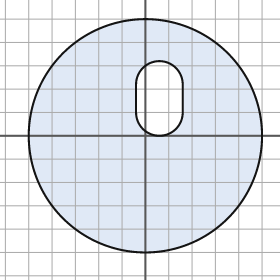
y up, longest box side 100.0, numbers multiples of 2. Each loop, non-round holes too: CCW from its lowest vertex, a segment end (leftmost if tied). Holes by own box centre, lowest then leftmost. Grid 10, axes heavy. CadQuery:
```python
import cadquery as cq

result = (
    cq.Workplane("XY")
    .moveTo(0.0, 0.0)
    .circle(50.0)
    .moveTo(-4.0, 10.0)
    .threePointArc((6.0, 0.0), (16.0, 10.0))
    .lineTo(16.0, 22.0)
    .threePointArc((6.0, 32.0), (-4.0, 22.0))
    .close()
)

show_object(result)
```